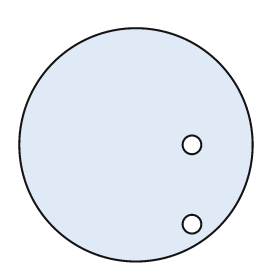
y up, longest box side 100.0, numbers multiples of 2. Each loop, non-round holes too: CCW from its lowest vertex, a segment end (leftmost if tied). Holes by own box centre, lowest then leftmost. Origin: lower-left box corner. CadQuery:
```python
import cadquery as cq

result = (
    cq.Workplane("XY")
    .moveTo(50.0, 50.0)
    .circle(50.0)
    .moveTo(74.0, 16.0)
    .circle(4.0)
    .moveTo(74.0, 50.0)
    .circle(4.0)
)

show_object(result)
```